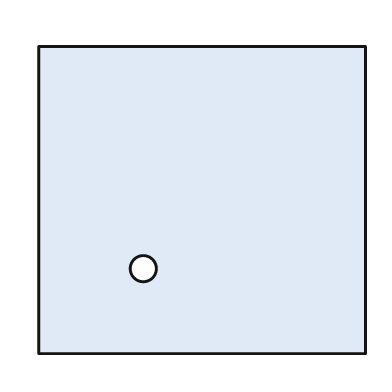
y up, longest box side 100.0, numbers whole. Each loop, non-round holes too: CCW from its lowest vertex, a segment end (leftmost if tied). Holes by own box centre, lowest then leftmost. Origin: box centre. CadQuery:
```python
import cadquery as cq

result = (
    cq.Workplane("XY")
    .moveTo(-50.0, -47.0)
    .lineTo(50.0, -47.0)
    .lineTo(50.0, 47.0)
    .lineTo(-50.0, 47.0)
    .close()
    .moveTo(-18.0, -21.0)
    .circle(4.0)
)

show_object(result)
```